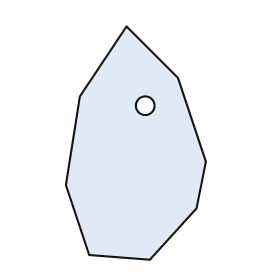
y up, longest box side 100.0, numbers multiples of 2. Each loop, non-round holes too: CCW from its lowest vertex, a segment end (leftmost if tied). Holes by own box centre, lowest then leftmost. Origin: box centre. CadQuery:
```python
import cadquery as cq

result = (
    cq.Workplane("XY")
    .moveTo(6.0, -50.0)
    .lineTo(26.0, -28.0)
    .lineTo(30.0, -8.0)
    .lineTo(18.0, 28.0)
    .lineTo(-4.0, 50.0)
    .lineTo(-24.0, 20.0)
    .lineTo(-30.0, -18.0)
    .lineTo(-20.0, -48.0)
    .close()
    .moveTo(4.0, 16.0)
    .circle(4.0)
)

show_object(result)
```